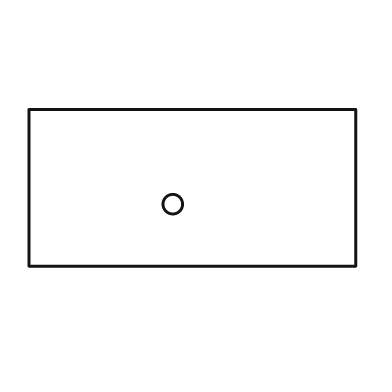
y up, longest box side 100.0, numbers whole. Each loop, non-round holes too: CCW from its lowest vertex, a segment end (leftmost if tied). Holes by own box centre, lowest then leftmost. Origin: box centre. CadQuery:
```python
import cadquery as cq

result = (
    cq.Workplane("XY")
    .moveTo(-50.0, -24.0)
    .lineTo(50.0, -24.0)
    .lineTo(50.0, 24.0)
    .lineTo(-50.0, 24.0)
    .close()
    .moveTo(-6.0, -5.0)
    .circle(3.0)
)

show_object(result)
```